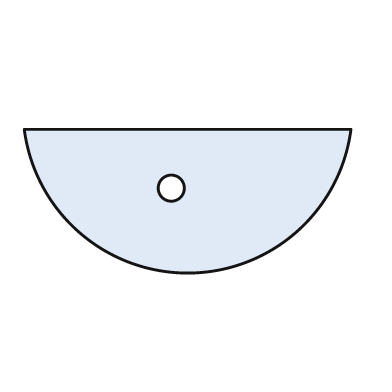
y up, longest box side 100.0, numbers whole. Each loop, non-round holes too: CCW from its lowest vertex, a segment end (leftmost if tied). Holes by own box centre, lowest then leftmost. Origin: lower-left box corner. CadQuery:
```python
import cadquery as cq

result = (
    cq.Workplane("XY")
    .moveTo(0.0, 44.0)
    .threePointArc((50.0, 0.0), (100.0, 44.0))
    .close()
    .moveTo(45.0, 26.0)
    .circle(4.0)
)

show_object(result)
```